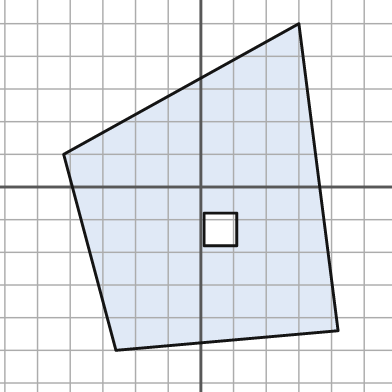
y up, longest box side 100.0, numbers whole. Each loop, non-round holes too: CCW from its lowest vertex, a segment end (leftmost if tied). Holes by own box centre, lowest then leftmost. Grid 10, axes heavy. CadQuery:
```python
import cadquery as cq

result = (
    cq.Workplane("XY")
    .moveTo(-26.0, -50.0)
    .lineTo(42.0, -44.0)
    .lineTo(30.0, 50.0)
    .lineTo(-42.0, 10.0)
    .close()
    .moveTo(1.0, -18.0)
    .lineTo(11.0, -18.0)
    .lineTo(11.0, -8.0)
    .lineTo(1.0, -8.0)
    .close()
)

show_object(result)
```